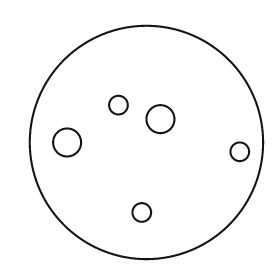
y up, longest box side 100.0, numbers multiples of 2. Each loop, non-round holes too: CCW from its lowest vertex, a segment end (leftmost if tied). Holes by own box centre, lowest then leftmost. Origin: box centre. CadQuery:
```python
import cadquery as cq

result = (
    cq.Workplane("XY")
    .moveTo(0.0, 0.0)
    .circle(50.0)
    .moveTo(-2.0, -30.0)
    .circle(4.0)
    .moveTo(40.0, -4.0)
    .circle(4.0)
    .moveTo(-34.0, 0.0)
    .circle(6.0)
    .moveTo(6.0, 10.0)
    .circle(6.0)
    .moveTo(-12.0, 16.0)
    .circle(4.0)
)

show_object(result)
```